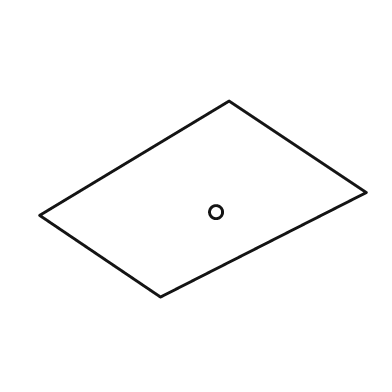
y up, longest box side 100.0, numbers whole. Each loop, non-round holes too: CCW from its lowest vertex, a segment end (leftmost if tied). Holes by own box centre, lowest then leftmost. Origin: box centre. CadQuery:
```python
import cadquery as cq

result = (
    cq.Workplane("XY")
    .moveTo(-13.0, -30.0)
    .lineTo(50.0, 2.0)
    .lineTo(8.0, 30.0)
    .lineTo(-50.0, -5.0)
    .close()
    .moveTo(4.0, -4.0)
    .circle(2.0)
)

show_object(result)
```